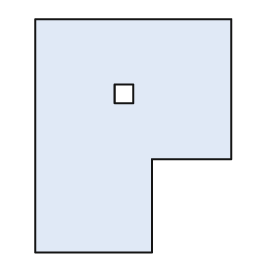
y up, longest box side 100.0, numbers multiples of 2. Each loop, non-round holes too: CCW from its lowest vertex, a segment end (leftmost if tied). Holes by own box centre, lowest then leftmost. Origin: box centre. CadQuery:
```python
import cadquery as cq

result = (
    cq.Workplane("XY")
    .moveTo(-42.0, -50.0)
    .lineTo(8.0, -50.0)
    .lineTo(8.0, -10.0)
    .lineTo(42.0, -10.0)
    .lineTo(42.0, 50.0)
    .lineTo(-42.0, 50.0)
    .close()
    .moveTo(-8.0, 14.0)
    .lineTo(0.0, 14.0)
    .lineTo(0.0, 22.0)
    .lineTo(-8.0, 22.0)
    .close()
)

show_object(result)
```